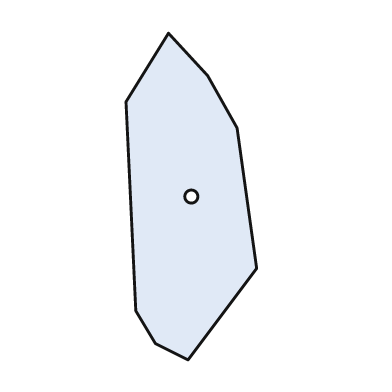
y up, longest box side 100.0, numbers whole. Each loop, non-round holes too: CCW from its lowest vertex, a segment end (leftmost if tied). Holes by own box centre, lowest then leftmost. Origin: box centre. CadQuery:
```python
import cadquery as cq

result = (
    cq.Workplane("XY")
    .moveTo(-1.0, -50.0)
    .lineTo(20.0, -22.0)
    .lineTo(14.0, 21.0)
    .lineTo(5.0, 37.0)
    .lineTo(-7.0, 50.0)
    .lineTo(-20.0, 29.0)
    .lineTo(-17.0, -35.0)
    .lineTo(-11.0, -45.0)
    .close()
    .moveTo(0.0, 0.0)
    .circle(2.0)
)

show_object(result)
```